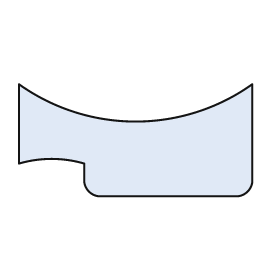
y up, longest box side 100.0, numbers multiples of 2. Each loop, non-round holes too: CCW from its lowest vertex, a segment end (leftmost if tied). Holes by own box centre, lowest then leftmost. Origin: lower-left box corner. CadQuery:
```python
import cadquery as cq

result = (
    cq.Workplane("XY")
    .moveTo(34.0, 0.0)
    .lineTo(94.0, 0.0)
    .threePointArc((98.0, 2.0), (100.0, 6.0))
    .lineTo(100.0, 48.0)
    .threePointArc((50.0, 32.0), (0.0, 48.0))
    .lineTo(0.0, 14.0)
    .threePointArc((14.0, 16.0), (28.0, 14.0))
    .lineTo(28.0, 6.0)
    .threePointArc((30.0, 2.0), (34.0, 0.0))
    .close()
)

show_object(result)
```